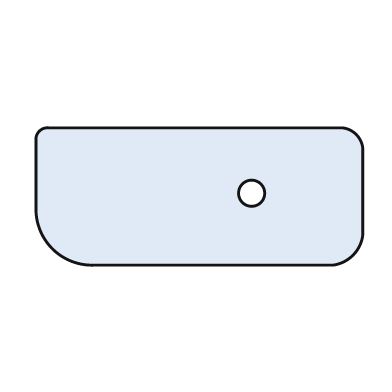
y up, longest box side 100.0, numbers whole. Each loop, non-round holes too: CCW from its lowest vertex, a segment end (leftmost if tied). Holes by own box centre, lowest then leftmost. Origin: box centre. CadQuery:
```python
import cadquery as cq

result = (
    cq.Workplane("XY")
    .moveTo(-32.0, -21.0)
    .lineTo(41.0, -21.0)
    .threePointArc((47.0, -18.0), (50.0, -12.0))
    .lineTo(50.0, 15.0)
    .threePointArc((48.0, 19.0), (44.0, 21.0))
    .lineTo(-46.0, 21.0)
    .threePointArc((-49.0, 20.0), (-50.0, 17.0))
    .lineTo(-50.0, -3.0)
    .threePointArc((-45.0, -16.0), (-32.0, -21.0))
    .close()
    .moveTo(16.0, 1.0)
    .circle(4.0)
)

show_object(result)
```